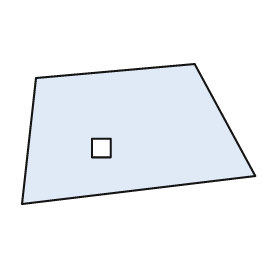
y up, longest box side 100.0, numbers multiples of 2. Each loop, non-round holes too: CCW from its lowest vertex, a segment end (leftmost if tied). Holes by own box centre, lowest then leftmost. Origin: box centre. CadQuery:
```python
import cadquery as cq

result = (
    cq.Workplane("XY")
    .moveTo(-50.0, -30.0)
    .lineTo(50.0, -18.0)
    .lineTo(24.0, 30.0)
    .lineTo(-44.0, 24.0)
    .close()
    .moveTo(-20.0, -10.0)
    .lineTo(-12.0, -10.0)
    .lineTo(-12.0, -2.0)
    .lineTo(-20.0, -2.0)
    .close()
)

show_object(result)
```